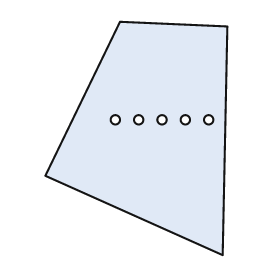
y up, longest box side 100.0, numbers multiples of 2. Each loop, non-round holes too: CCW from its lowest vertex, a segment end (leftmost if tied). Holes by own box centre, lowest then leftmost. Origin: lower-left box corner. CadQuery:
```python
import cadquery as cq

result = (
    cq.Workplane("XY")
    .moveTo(76.0, 0.0)
    .lineTo(78.0, 98.0)
    .lineTo(32.0, 100.0)
    .lineTo(0.0, 34.0)
    .close()
    .moveTo(30.0, 58.0)
    .circle(2.0)
    .moveTo(40.0, 58.0)
    .circle(2.0)
    .moveTo(50.0, 58.0)
    .circle(2.0)
    .moveTo(60.0, 58.0)
    .circle(2.0)
    .moveTo(70.0, 58.0)
    .circle(2.0)
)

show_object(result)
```